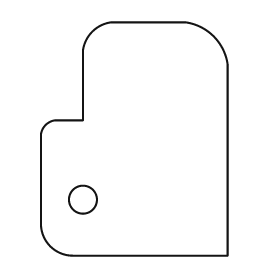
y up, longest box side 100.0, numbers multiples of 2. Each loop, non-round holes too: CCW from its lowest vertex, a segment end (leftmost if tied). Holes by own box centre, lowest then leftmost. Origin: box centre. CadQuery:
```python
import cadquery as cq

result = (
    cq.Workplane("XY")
    .moveTo(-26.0, -50.0)
    .lineTo(40.0, -50.0)
    .lineTo(40.0, 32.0)
    .threePointArc((34.0, 44.0), (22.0, 50.0))
    .lineTo(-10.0, 50.0)
    .threePointArc((-18.0, 46.0), (-22.0, 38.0))
    .lineTo(-22.0, 8.0)
    .lineTo(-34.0, 8.0)
    .threePointArc((-38.0, 6.0), (-40.0, 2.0))
    .lineTo(-40.0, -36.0)
    .threePointArc((-36.0, -46.0), (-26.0, -50.0))
    .close()
    .moveTo(-22.0, -26.0)
    .circle(6.0)
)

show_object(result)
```